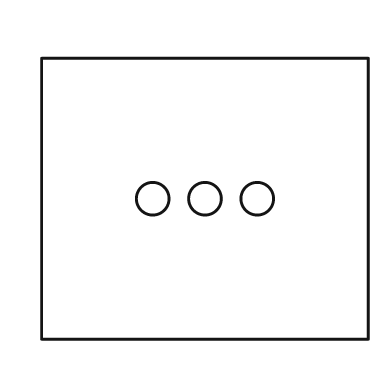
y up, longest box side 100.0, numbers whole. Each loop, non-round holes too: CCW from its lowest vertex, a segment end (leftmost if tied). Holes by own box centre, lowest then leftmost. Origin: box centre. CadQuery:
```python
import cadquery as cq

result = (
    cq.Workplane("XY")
    .moveTo(-50.0, -43.0)
    .lineTo(50.0, -43.0)
    .lineTo(50.0, 43.0)
    .lineTo(-50.0, 43.0)
    .close()
    .moveTo(-16.0, 0.0)
    .circle(5.0)
    .moveTo(0.0, 0.0)
    .circle(5.0)
    .moveTo(16.0, 0.0)
    .circle(5.0)
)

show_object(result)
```